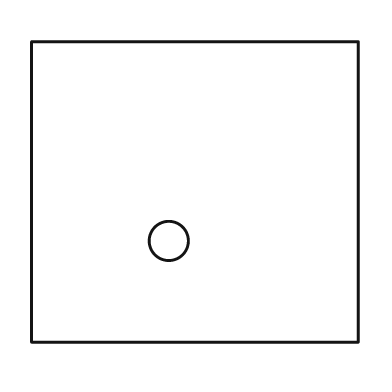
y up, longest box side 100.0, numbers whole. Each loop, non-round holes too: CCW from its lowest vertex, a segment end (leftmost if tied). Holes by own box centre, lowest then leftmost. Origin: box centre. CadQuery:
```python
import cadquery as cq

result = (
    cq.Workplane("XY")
    .moveTo(-50.0, -46.0)
    .lineTo(50.0, -46.0)
    .lineTo(50.0, 46.0)
    .lineTo(-50.0, 46.0)
    .close()
    .moveTo(-8.0, -15.0)
    .circle(6.0)
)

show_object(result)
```